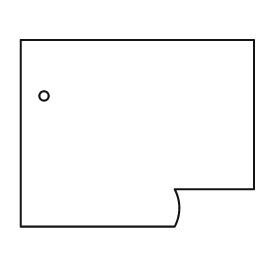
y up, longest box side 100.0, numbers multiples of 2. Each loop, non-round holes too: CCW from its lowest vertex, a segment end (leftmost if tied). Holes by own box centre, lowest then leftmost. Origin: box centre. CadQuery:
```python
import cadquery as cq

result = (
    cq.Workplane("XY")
    .moveTo(-50.0, -40.0)
    .lineTo(16.0, -40.0)
    .threePointArc((18.0, -32.0), (16.0, -24.0))
    .lineTo(50.0, -24.0)
    .lineTo(50.0, 40.0)
    .lineTo(-50.0, 40.0)
    .close()
    .moveTo(-40.0, 16.0)
    .circle(2.0)
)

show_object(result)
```